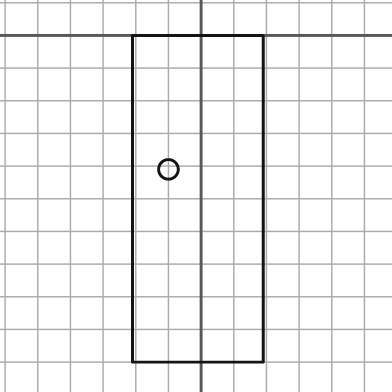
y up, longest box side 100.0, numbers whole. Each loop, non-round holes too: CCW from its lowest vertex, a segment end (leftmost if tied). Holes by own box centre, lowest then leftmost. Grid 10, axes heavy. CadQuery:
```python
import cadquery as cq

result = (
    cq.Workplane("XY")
    .moveTo(-21.0, -100.0)
    .lineTo(19.0, -100.0)
    .lineTo(19.0, 0.0)
    .lineTo(-21.0, 0.0)
    .close()
    .moveTo(-10.0, -41.0)
    .circle(3.0)
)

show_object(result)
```